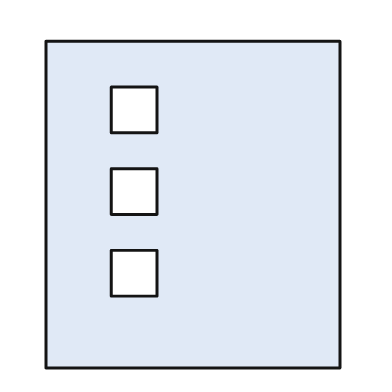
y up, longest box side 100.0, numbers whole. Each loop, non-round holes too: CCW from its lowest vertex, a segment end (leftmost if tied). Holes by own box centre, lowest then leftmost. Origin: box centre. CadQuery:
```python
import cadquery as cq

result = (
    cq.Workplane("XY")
    .moveTo(-45.0, -50.0)
    .lineTo(45.0, -50.0)
    .lineTo(45.0, 50.0)
    .lineTo(-45.0, 50.0)
    .close()
    .moveTo(-25.0, -28.0)
    .lineTo(-11.0, -28.0)
    .lineTo(-11.0, -14.0)
    .lineTo(-25.0, -14.0)
    .close()
    .moveTo(-25.0, -3.0)
    .lineTo(-11.0, -3.0)
    .lineTo(-11.0, 11.0)
    .lineTo(-25.0, 11.0)
    .close()
    .moveTo(-25.0, 22.0)
    .lineTo(-11.0, 22.0)
    .lineTo(-11.0, 36.0)
    .lineTo(-25.0, 36.0)
    .close()
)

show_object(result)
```